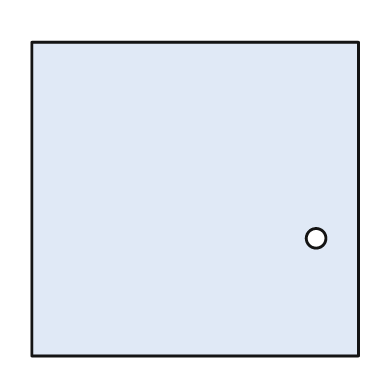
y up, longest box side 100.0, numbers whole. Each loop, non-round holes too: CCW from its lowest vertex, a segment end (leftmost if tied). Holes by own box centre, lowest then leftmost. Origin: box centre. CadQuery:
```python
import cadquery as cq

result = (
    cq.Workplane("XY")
    .moveTo(-50.0, -48.0)
    .lineTo(50.0, -48.0)
    .lineTo(50.0, 48.0)
    .lineTo(-50.0, 48.0)
    .close()
    .moveTo(37.0, -12.0)
    .circle(3.0)
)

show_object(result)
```